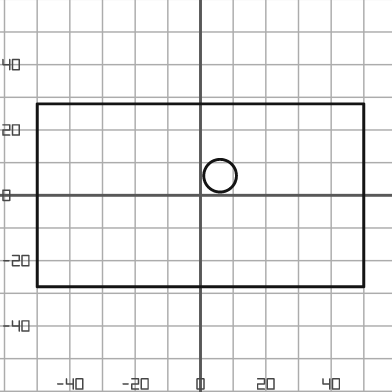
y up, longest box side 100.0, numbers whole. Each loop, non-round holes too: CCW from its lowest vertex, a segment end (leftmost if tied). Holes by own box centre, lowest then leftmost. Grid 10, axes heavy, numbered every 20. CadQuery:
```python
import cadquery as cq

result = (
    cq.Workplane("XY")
    .moveTo(-50.0, -28.0)
    .lineTo(50.0, -28.0)
    .lineTo(50.0, 28.0)
    .lineTo(-50.0, 28.0)
    .close()
    .moveTo(6.0, 6.0)
    .circle(5.0)
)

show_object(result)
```